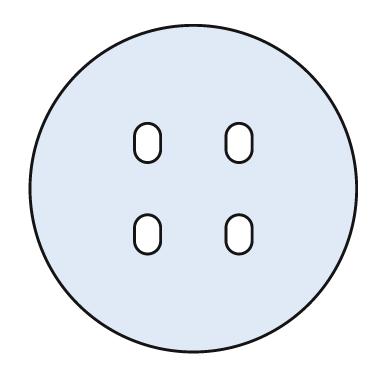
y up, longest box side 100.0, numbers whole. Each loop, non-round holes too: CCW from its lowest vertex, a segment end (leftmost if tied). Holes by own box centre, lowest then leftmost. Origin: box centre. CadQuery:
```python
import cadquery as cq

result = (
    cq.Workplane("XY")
    .moveTo(0.0, 0.0)
    .circle(50.0)
    .moveTo(-18.0, -16.0)
    .threePointArc((-14.0, -20.0), (-10.0, -16.0))
    .lineTo(-10.0, -12.0)
    .threePointArc((-14.0, -8.0), (-18.0, -12.0))
    .close()
    .moveTo(10.0, -16.0)
    .threePointArc((14.0, -20.0), (18.0, -16.0))
    .lineTo(18.0, -12.0)
    .threePointArc((14.0, -8.0), (10.0, -12.0))
    .close()
    .moveTo(-18.0, 12.0)
    .threePointArc((-14.0, 8.0), (-10.0, 12.0))
    .lineTo(-10.0, 16.0)
    .threePointArc((-14.0, 20.0), (-18.0, 16.0))
    .close()
    .moveTo(10.0, 12.0)
    .threePointArc((14.0, 8.0), (18.0, 12.0))
    .lineTo(18.0, 16.0)
    .threePointArc((14.0, 20.0), (10.0, 16.0))
    .close()
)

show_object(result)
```